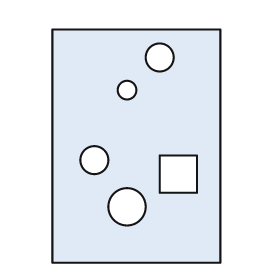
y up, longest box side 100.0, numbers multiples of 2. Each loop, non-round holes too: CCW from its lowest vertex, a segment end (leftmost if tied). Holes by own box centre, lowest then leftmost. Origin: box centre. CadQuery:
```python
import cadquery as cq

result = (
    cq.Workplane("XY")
    .moveTo(-36.0, -50.0)
    .lineTo(36.0, -50.0)
    .lineTo(36.0, 50.0)
    .lineTo(-36.0, 50.0)
    .close()
    .moveTo(-4.0, -26.0)
    .circle(8.0)
    .moveTo(10.0, -20.0)
    .lineTo(26.0, -20.0)
    .lineTo(26.0, -4.0)
    .lineTo(10.0, -4.0)
    .close()
    .moveTo(-18.0, -6.0)
    .circle(6.0)
    .moveTo(-4.0, 24.0)
    .circle(4.0)
    .moveTo(10.0, 38.0)
    .circle(6.0)
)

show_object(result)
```